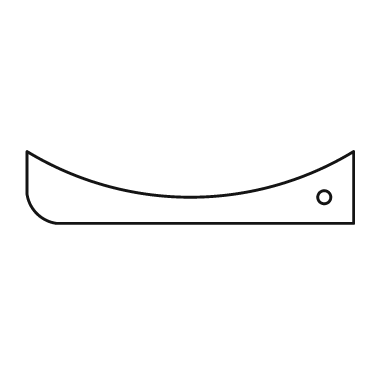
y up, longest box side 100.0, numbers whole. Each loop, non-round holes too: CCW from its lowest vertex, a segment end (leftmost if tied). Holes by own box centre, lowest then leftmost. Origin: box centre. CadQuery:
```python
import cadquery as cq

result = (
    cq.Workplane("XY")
    .moveTo(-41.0, -11.0)
    .lineTo(50.0, -11.0)
    .lineTo(50.0, 11.0)
    .threePointArc((0.0, -3.0), (-50.0, 11.0))
    .lineTo(-50.0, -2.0)
    .threePointArc((-47.0, -8.0), (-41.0, -11.0))
    .close()
    .moveTo(41.0, -3.0)
    .circle(2.0)
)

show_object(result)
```